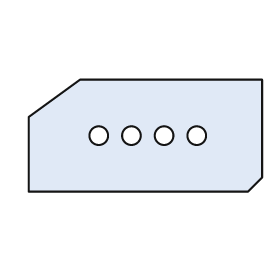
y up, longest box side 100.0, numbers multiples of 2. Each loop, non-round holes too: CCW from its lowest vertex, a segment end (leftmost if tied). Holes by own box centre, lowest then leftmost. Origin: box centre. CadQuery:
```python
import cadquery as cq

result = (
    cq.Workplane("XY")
    .moveTo(-50.0, -24.0)
    .lineTo(44.0, -24.0)
    .lineTo(50.0, -18.0)
    .lineTo(50.0, 24.0)
    .lineTo(-28.0, 24.0)
    .lineTo(-50.0, 8.0)
    .close()
    .moveTo(-20.0, 0.0)
    .circle(4.0)
    .moveTo(-6.0, 0.0)
    .circle(4.0)
    .moveTo(8.0, 0.0)
    .circle(4.0)
    .moveTo(22.0, 0.0)
    .circle(4.0)
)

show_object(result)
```